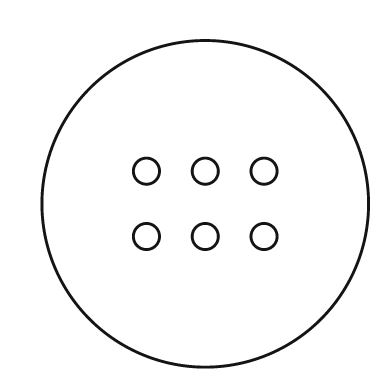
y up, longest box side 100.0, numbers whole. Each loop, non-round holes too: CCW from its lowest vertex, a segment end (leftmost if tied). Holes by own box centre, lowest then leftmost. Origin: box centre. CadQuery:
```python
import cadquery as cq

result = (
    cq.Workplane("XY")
    .moveTo(0.0, 0.0)
    .circle(50.0)
    .moveTo(-18.0, -10.0)
    .circle(4.0)
    .moveTo(0.0, -10.0)
    .circle(4.0)
    .moveTo(18.0, -10.0)
    .circle(4.0)
    .moveTo(-18.0, 10.0)
    .circle(4.0)
    .moveTo(0.0, 10.0)
    .circle(4.0)
    .moveTo(18.0, 10.0)
    .circle(4.0)
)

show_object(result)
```